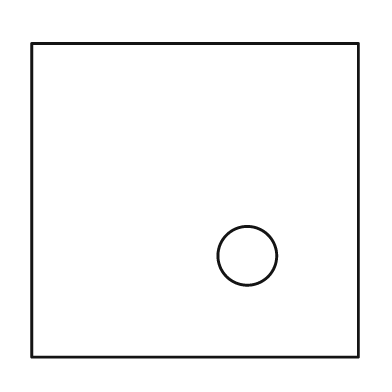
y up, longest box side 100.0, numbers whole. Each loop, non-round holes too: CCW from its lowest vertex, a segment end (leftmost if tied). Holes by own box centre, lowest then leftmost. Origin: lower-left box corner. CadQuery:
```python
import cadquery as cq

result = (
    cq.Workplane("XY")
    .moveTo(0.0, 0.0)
    .lineTo(100.0, 0.0)
    .lineTo(100.0, 96.0)
    .lineTo(0.0, 96.0)
    .close()
    .moveTo(66.0, 31.0)
    .circle(9.0)
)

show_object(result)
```